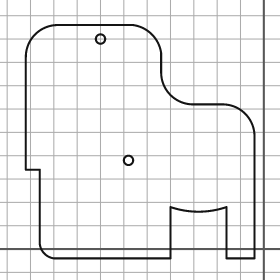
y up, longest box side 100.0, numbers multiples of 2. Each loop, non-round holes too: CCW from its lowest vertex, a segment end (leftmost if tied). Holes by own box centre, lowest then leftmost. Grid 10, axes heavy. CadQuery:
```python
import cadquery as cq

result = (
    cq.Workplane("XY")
    .moveTo(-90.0, -4.0)
    .lineTo(-40.0, -4.0)
    .lineTo(-40.0, 18.0)
    .threePointArc((-28.0, 16.0), (-16.0, 18.0))
    .lineTo(-16.0, -4.0)
    .lineTo(-4.0, -4.0)
    .lineTo(-4.0, 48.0)
    .threePointArc((-8.0, 58.0), (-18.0, 62.0))
    .lineTo(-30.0, 62.0)
    .threePointArc((-40.0, 66.0), (-44.0, 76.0))
    .lineTo(-44.0, 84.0)
    .threePointArc((-48.0, 92.0), (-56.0, 96.0))
    .lineTo(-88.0, 96.0)
    .threePointArc((-98.0, 92.0), (-102.0, 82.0))
    .lineTo(-102.0, 34.0)
    .lineTo(-96.0, 34.0)
    .lineTo(-96.0, 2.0)
    .threePointArc((-94.0, -2.0), (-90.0, -4.0))
    .close()
    .moveTo(-58.0, 38.0)
    .circle(2.0)
    .moveTo(-70.0, 90.0)
    .circle(2.0)
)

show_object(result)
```